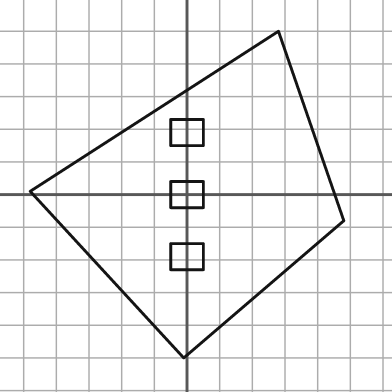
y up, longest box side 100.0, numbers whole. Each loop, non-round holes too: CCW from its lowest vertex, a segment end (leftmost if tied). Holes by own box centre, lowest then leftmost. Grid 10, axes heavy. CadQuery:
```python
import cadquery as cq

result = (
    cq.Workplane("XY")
    .moveTo(-1.0, -50.0)
    .lineTo(48.0, -8.0)
    .lineTo(28.0, 50.0)
    .lineTo(-48.0, 1.0)
    .close()
    .moveTo(-5.0, -23.0)
    .lineTo(5.0, -23.0)
    .lineTo(5.0, -15.0)
    .lineTo(-5.0, -15.0)
    .close()
    .moveTo(-5.0, -4.0)
    .lineTo(5.0, -4.0)
    .lineTo(5.0, 4.0)
    .lineTo(-5.0, 4.0)
    .close()
    .moveTo(-5.0, 15.0)
    .lineTo(5.0, 15.0)
    .lineTo(5.0, 23.0)
    .lineTo(-5.0, 23.0)
    .close()
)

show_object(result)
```